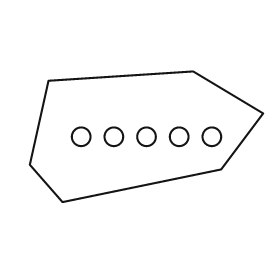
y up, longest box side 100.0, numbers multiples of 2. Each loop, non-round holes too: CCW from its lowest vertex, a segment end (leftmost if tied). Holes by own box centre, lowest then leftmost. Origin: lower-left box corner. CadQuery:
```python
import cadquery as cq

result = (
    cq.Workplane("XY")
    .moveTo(14.0, 0.0)
    .lineTo(82.0, 14.0)
    .lineTo(100.0, 38.0)
    .lineTo(70.0, 56.0)
    .lineTo(8.0, 52.0)
    .lineTo(0.0, 16.0)
    .close()
    .moveTo(22.0, 28.0)
    .circle(4.0)
    .moveTo(36.0, 28.0)
    .circle(4.0)
    .moveTo(50.0, 28.0)
    .circle(4.0)
    .moveTo(64.0, 28.0)
    .circle(4.0)
    .moveTo(78.0, 28.0)
    .circle(4.0)
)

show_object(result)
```